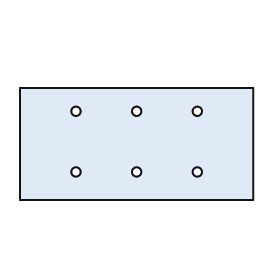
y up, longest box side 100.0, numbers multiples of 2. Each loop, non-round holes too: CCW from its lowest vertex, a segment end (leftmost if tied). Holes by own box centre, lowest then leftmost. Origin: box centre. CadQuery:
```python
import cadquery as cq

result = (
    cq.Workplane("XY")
    .moveTo(-50.0, -24.0)
    .lineTo(50.0, -24.0)
    .lineTo(50.0, 24.0)
    .lineTo(-50.0, 24.0)
    .close()
    .moveTo(-26.0, -12.0)
    .circle(2.0)
    .moveTo(0.0, -12.0)
    .circle(2.0)
    .moveTo(26.0, -12.0)
    .circle(2.0)
    .moveTo(-26.0, 14.0)
    .circle(2.0)
    .moveTo(0.0, 14.0)
    .circle(2.0)
    .moveTo(26.0, 14.0)
    .circle(2.0)
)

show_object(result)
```